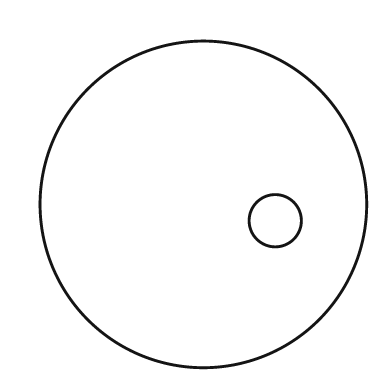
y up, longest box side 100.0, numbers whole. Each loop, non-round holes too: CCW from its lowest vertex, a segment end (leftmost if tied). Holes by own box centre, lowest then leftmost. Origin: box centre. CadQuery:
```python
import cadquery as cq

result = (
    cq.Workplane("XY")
    .moveTo(0.0, 0.0)
    .circle(50.0)
    .moveTo(22.0, -5.0)
    .circle(8.0)
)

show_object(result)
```